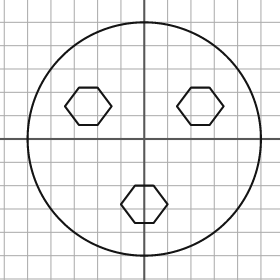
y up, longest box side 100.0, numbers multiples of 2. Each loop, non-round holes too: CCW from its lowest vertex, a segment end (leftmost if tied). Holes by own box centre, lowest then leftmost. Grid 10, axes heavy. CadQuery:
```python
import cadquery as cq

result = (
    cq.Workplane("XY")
    .moveTo(0.0, 0.0)
    .circle(50.0)
    .moveTo(-4.0, -36.0)
    .lineTo(4.0, -36.0)
    .lineTo(10.0, -28.0)
    .lineTo(4.0, -20.0)
    .lineTo(-4.0, -20.0)
    .lineTo(-10.0, -28.0)
    .close()
    .moveTo(-28.0, 6.0)
    .lineTo(-20.0, 6.0)
    .lineTo(-14.0, 14.0)
    .lineTo(-20.0, 22.0)
    .lineTo(-28.0, 22.0)
    .lineTo(-34.0, 14.0)
    .close()
    .moveTo(20.0, 6.0)
    .lineTo(28.0, 6.0)
    .lineTo(34.0, 14.0)
    .lineTo(28.0, 22.0)
    .lineTo(20.0, 22.0)
    .lineTo(14.0, 14.0)
    .close()
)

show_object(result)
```